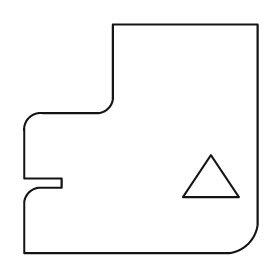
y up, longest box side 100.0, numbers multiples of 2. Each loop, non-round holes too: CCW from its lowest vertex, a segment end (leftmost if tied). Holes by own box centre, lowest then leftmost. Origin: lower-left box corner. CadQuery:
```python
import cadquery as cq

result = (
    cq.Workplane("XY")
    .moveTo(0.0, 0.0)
    .lineTo(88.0, 0.0)
    .threePointArc((96.0, 4.0), (100.0, 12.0))
    .lineTo(100.0, 98.0)
    .lineTo(38.0, 98.0)
    .lineTo(38.0, 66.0)
    .threePointArc((36.0, 62.0), (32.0, 60.0))
    .lineTo(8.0, 60.0)
    .threePointArc((2.0, 58.0), (0.0, 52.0))
    .lineTo(0.0, 32.0)
    .lineTo(16.0, 32.0)
    .lineTo(16.0, 28.0)
    .lineTo(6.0, 28.0)
    .threePointArc((2.0, 26.0), (0.0, 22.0))
    .close()
    .moveTo(68.0, 24.0)
    .lineTo(92.0, 24.0)
    .lineTo(80.0, 42.0)
    .close()
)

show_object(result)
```